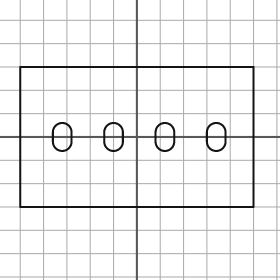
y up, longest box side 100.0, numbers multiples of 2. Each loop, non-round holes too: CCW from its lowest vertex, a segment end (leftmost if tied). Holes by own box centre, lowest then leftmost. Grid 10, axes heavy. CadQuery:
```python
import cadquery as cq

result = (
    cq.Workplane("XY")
    .moveTo(-50.0, -30.0)
    .lineTo(50.0, -30.0)
    .lineTo(50.0, 30.0)
    .lineTo(-50.0, 30.0)
    .close()
    .moveTo(-36.0, -2.0)
    .threePointArc((-32.0, -6.0), (-28.0, -2.0))
    .lineTo(-28.0, 2.0)
    .threePointArc((-32.0, 6.0), (-36.0, 2.0))
    .close()
    .moveTo(-14.0, -2.0)
    .threePointArc((-10.0, -6.0), (-6.0, -2.0))
    .lineTo(-6.0, 2.0)
    .threePointArc((-10.0, 6.0), (-14.0, 2.0))
    .close()
    .moveTo(8.0, -2.0)
    .threePointArc((12.0, -6.0), (16.0, -2.0))
    .lineTo(16.0, 2.0)
    .threePointArc((12.0, 6.0), (8.0, 2.0))
    .close()
    .moveTo(30.0, -2.0)
    .threePointArc((34.0, -6.0), (38.0, -2.0))
    .lineTo(38.0, 2.0)
    .threePointArc((34.0, 6.0), (30.0, 2.0))
    .close()
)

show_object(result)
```